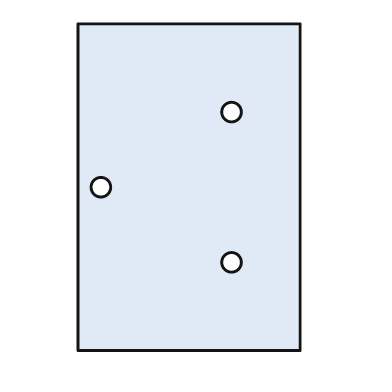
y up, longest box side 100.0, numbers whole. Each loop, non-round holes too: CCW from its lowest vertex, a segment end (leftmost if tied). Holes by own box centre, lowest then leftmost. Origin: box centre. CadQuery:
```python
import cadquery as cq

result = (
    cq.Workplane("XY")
    .moveTo(-34.0, -50.0)
    .lineTo(34.0, -50.0)
    .lineTo(34.0, 50.0)
    .lineTo(-34.0, 50.0)
    .close()
    .moveTo(13.0, -23.0)
    .circle(3.0)
    .moveTo(-27.0, 0.0)
    .circle(3.0)
    .moveTo(13.0, 23.0)
    .circle(3.0)
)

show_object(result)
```